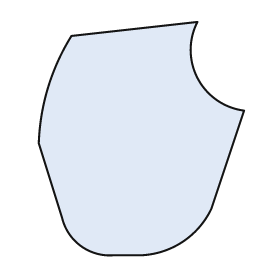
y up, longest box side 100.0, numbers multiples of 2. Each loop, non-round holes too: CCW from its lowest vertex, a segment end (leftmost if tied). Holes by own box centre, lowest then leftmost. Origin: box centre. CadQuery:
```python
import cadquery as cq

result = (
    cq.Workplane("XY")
    .moveTo(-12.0, -50.0)
    .lineTo(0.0, -50.0)
    .threePointArc((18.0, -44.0), (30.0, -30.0))
    .lineTo(44.0, 12.0)
    .threePointArc((24.0, 26.0), (24.0, 50.0))
    .lineTo(-30.0, 44.0)
    .threePointArc((-40.0, 22.0), (-44.0, -2.0))
    .lineTo(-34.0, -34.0)
    .threePointArc((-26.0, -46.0), (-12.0, -50.0))
    .close()
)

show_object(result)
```